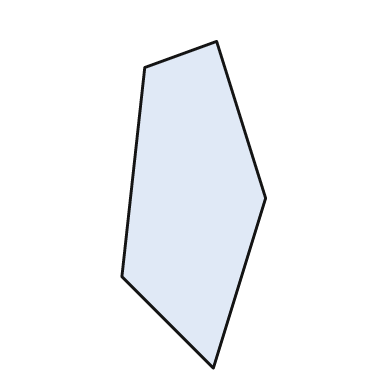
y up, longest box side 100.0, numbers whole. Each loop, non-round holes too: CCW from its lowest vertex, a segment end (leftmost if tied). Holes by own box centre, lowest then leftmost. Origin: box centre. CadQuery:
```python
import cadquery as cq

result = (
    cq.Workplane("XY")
    .moveTo(6.0, -50.0)
    .lineTo(22.0, 2.0)
    .lineTo(7.0, 50.0)
    .lineTo(-15.0, 42.0)
    .lineTo(-22.0, -22.0)
    .close()
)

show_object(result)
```